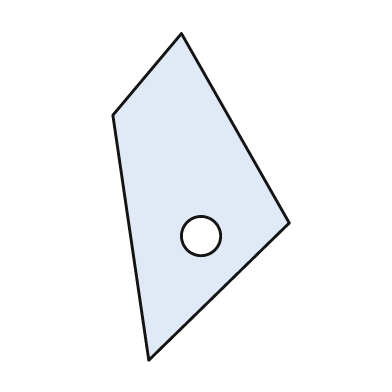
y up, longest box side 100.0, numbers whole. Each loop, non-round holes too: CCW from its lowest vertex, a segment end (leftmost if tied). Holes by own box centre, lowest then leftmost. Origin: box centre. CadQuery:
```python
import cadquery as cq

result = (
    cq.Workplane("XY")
    .moveTo(-16.0, -50.0)
    .lineTo(27.0, -8.0)
    .lineTo(-6.0, 50.0)
    .lineTo(-27.0, 25.0)
    .close()
    .moveTo(0.0, -12.0)
    .circle(6.0)
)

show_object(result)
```